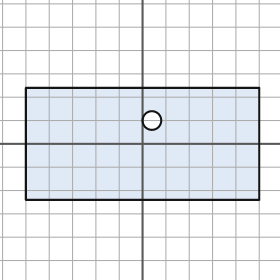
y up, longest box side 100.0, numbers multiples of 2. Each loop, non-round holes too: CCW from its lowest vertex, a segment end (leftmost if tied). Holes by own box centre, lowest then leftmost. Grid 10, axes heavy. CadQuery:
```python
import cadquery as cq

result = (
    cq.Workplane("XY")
    .moveTo(-50.0, -24.0)
    .lineTo(50.0, -24.0)
    .lineTo(50.0, 24.0)
    .lineTo(-50.0, 24.0)
    .close()
    .moveTo(4.0, 10.0)
    .circle(4.0)
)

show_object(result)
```